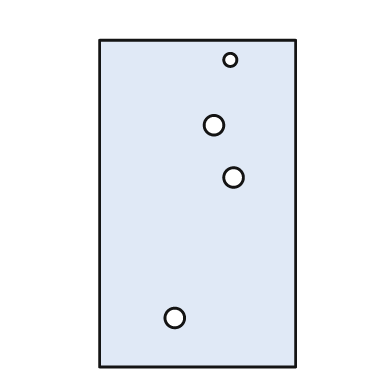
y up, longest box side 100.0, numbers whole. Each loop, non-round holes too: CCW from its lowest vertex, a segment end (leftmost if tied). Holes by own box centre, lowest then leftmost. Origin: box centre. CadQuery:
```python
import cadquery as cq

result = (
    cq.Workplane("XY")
    .moveTo(-30.0, -50.0)
    .lineTo(30.0, -50.0)
    .lineTo(30.0, 50.0)
    .lineTo(-30.0, 50.0)
    .close()
    .moveTo(-7.0, -35.0)
    .circle(3.0)
    .moveTo(11.0, 8.0)
    .circle(3.0)
    .moveTo(5.0, 24.0)
    .circle(3.0)
    .moveTo(10.0, 44.0)
    .circle(2.0)
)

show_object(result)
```